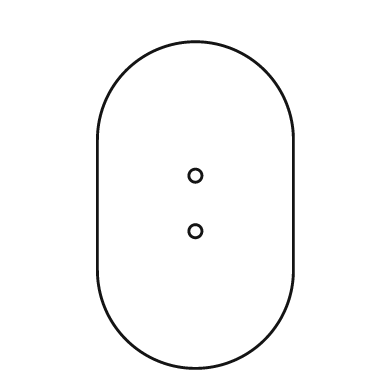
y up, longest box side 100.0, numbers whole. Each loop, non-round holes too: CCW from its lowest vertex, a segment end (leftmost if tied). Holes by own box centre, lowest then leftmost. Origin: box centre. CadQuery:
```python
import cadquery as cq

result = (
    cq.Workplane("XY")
    .moveTo(-30.0, -20.0)
    .threePointArc((0.0, -50.0), (30.0, -20.0))
    .lineTo(30.0, 20.0)
    .threePointArc((0.0, 50.0), (-30.0, 20.0))
    .close()
    .moveTo(0.0, -8.0)
    .circle(2.0)
    .moveTo(0.0, 9.0)
    .circle(2.0)
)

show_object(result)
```